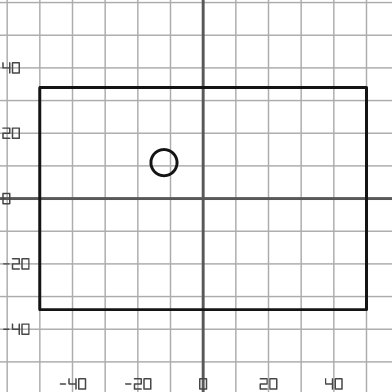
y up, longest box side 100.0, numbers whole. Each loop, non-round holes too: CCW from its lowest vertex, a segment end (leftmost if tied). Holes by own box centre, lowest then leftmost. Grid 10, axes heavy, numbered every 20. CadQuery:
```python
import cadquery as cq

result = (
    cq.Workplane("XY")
    .moveTo(-50.0, -34.0)
    .lineTo(50.0, -34.0)
    .lineTo(50.0, 34.0)
    .lineTo(-50.0, 34.0)
    .close()
    .moveTo(-12.0, 11.0)
    .circle(4.0)
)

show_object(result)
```